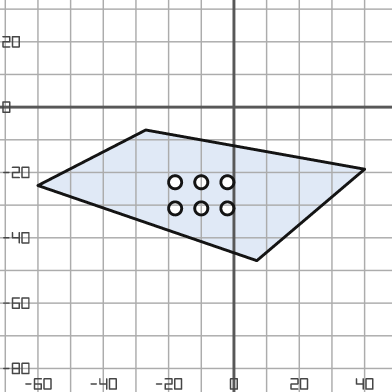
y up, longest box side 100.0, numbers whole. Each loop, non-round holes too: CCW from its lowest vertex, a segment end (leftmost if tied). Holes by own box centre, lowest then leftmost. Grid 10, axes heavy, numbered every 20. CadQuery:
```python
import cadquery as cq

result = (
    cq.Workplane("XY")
    .moveTo(7.0, -47.0)
    .lineTo(40.0, -19.0)
    .lineTo(-27.0, -7.0)
    .lineTo(-60.0, -24.0)
    .close()
    .moveTo(-18.0, -31.0)
    .circle(2.0)
    .moveTo(-10.0, -31.0)
    .circle(2.0)
    .moveTo(-2.0, -31.0)
    .circle(2.0)
    .moveTo(-18.0, -23.0)
    .circle(2.0)
    .moveTo(-10.0, -23.0)
    .circle(2.0)
    .moveTo(-2.0, -23.0)
    .circle(2.0)
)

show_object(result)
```